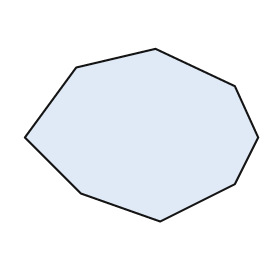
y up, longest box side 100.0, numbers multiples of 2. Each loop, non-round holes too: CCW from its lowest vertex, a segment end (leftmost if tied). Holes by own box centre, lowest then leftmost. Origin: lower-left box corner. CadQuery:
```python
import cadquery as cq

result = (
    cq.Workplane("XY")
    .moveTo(58.0, 0.0)
    .lineTo(90.0, 16.0)
    .lineTo(100.0, 36.0)
    .lineTo(90.0, 58.0)
    .lineTo(56.0, 74.0)
    .lineTo(22.0, 66.0)
    .lineTo(0.0, 36.0)
    .lineTo(24.0, 12.0)
    .close()
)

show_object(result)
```